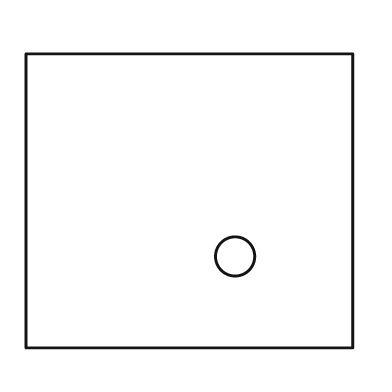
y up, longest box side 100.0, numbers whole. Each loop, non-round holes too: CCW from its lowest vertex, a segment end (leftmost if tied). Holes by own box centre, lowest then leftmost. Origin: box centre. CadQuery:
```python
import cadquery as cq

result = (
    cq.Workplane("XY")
    .moveTo(-50.0, -45.0)
    .lineTo(50.0, -45.0)
    .lineTo(50.0, 45.0)
    .lineTo(-50.0, 45.0)
    .close()
    .moveTo(14.0, -17.0)
    .circle(6.0)
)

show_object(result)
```